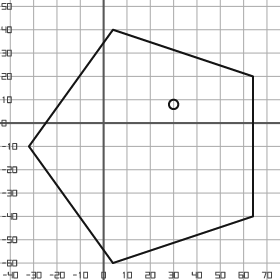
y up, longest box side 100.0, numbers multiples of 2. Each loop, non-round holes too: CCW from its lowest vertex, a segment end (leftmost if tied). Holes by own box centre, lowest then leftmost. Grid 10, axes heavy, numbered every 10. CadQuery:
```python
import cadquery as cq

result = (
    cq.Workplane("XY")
    .moveTo(4.0, -60.0)
    .lineTo(64.0, -40.0)
    .lineTo(64.0, 20.0)
    .lineTo(4.0, 40.0)
    .lineTo(-32.0, -10.0)
    .close()
    .moveTo(30.0, 8.0)
    .circle(2.0)
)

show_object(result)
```